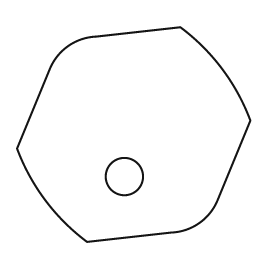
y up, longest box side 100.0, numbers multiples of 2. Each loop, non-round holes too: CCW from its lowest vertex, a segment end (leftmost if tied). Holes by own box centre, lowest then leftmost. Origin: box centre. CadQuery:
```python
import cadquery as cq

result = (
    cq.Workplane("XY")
    .moveTo(-20.0, -46.0)
    .lineTo(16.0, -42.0)
    .threePointArc((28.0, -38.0), (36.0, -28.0))
    .lineTo(50.0, 6.0)
    .threePointArc((38.0, 28.0), (20.0, 46.0))
    .lineTo(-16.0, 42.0)
    .threePointArc((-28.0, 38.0), (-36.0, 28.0))
    .lineTo(-50.0, -6.0)
    .threePointArc((-38.0, -28.0), (-20.0, -46.0))
    .close()
    .moveTo(-4.0, -18.0)
    .circle(8.0)
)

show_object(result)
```